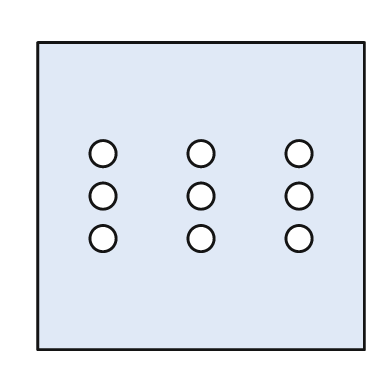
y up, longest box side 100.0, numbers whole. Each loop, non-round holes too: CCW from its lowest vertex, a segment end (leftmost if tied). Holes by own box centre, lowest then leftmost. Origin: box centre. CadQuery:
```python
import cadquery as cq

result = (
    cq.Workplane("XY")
    .moveTo(-50.0, -47.0)
    .lineTo(50.0, -47.0)
    .lineTo(50.0, 47.0)
    .lineTo(-50.0, 47.0)
    .close()
    .moveTo(-30.0, -13.0)
    .circle(4.0)
    .moveTo(0.0, -13.0)
    .circle(4.0)
    .moveTo(30.0, -13.0)
    .circle(4.0)
    .moveTo(-30.0, 0.0)
    .circle(4.0)
    .moveTo(0.0, 0.0)
    .circle(4.0)
    .moveTo(30.0, 0.0)
    .circle(4.0)
    .moveTo(-30.0, 13.0)
    .circle(4.0)
    .moveTo(0.0, 13.0)
    .circle(4.0)
    .moveTo(30.0, 13.0)
    .circle(4.0)
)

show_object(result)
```